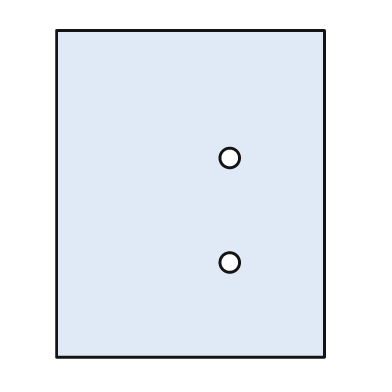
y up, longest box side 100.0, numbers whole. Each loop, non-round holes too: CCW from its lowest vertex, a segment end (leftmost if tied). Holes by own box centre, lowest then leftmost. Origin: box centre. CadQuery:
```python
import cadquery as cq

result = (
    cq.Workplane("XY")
    .moveTo(-41.0, -50.0)
    .lineTo(41.0, -50.0)
    .lineTo(41.0, 50.0)
    .lineTo(-41.0, 50.0)
    .close()
    .moveTo(12.0, -21.0)
    .circle(3.0)
    .moveTo(12.0, 11.0)
    .circle(3.0)
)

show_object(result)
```